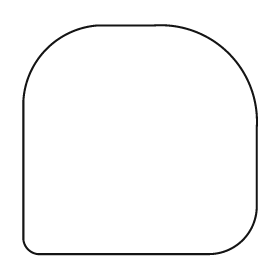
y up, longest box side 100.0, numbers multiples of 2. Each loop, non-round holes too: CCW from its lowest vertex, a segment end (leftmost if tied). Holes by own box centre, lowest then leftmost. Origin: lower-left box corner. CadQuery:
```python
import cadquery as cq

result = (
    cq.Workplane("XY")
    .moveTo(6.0, 0.0)
    .lineTo(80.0, 0.0)
    .threePointArc((94.0, 6.0), (100.0, 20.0))
    .lineTo(100.0, 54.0)
    .threePointArc((88.0, 86.0), (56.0, 98.0))
    .lineTo(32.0, 98.0)
    .threePointArc((10.0, 88.0), (0.0, 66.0))
    .lineTo(0.0, 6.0)
    .threePointArc((2.0, 2.0), (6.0, 0.0))
    .close()
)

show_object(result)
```